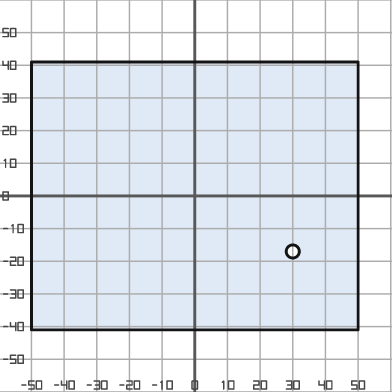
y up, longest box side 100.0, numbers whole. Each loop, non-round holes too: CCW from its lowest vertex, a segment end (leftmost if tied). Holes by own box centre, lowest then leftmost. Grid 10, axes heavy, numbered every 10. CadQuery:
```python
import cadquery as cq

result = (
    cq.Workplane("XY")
    .moveTo(-50.0, -41.0)
    .lineTo(50.0, -41.0)
    .lineTo(50.0, 41.0)
    .lineTo(-50.0, 41.0)
    .close()
    .moveTo(30.0, -17.0)
    .circle(2.0)
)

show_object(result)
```